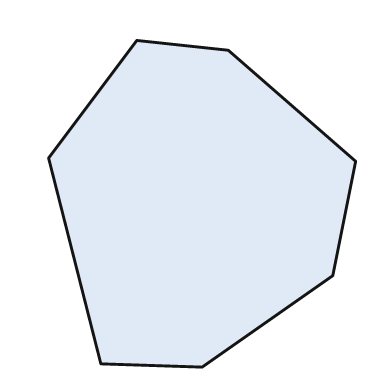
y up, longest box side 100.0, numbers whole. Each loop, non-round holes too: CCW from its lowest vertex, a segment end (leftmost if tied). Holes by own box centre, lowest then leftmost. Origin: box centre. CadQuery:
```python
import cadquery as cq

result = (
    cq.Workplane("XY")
    .moveTo(0.0, -50.0)
    .lineTo(40.0, -22.0)
    .lineTo(47.0, 13.0)
    .lineTo(8.0, 47.0)
    .lineTo(-20.0, 50.0)
    .lineTo(-47.0, 14.0)
    .lineTo(-31.0, -49.0)
    .close()
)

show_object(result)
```